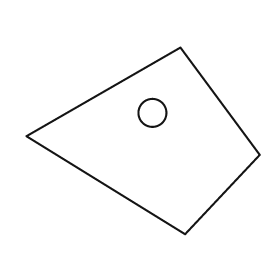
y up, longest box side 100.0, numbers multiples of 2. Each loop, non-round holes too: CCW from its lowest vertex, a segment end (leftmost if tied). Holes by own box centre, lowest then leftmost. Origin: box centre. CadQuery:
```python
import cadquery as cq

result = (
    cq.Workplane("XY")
    .moveTo(18.0, -40.0)
    .lineTo(50.0, -6.0)
    .lineTo(16.0, 40.0)
    .lineTo(-50.0, 2.0)
    .close()
    .moveTo(4.0, 12.0)
    .circle(6.0)
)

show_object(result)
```